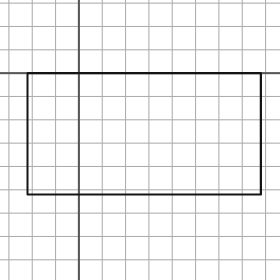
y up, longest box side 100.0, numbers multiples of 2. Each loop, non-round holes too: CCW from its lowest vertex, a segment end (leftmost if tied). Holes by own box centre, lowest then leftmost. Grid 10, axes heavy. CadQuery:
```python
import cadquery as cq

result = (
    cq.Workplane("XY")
    .moveTo(-22.0, -52.0)
    .lineTo(78.0, -52.0)
    .lineTo(78.0, 0.0)
    .lineTo(-22.0, 0.0)
    .close()
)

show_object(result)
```